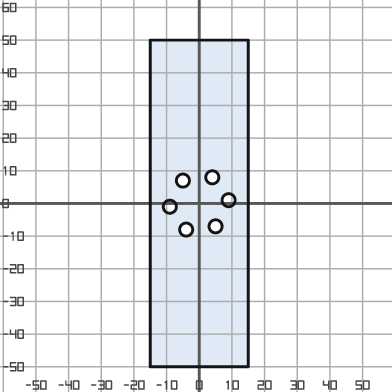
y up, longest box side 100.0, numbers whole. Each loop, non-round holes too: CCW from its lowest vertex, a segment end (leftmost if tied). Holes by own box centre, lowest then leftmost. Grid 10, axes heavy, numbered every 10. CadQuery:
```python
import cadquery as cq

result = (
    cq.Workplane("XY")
    .moveTo(-15.0, -50.0)
    .lineTo(15.0, -50.0)
    .lineTo(15.0, 50.0)
    .lineTo(-15.0, 50.0)
    .close()
    .moveTo(-4.0, -8.0)
    .circle(2.0)
    .moveTo(5.0, -7.0)
    .circle(2.0)
    .moveTo(-9.0, -1.0)
    .circle(2.0)
    .moveTo(9.0, 1.0)
    .circle(2.0)
    .moveTo(-5.0, 7.0)
    .circle(2.0)
    .moveTo(4.0, 8.0)
    .circle(2.0)
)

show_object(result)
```